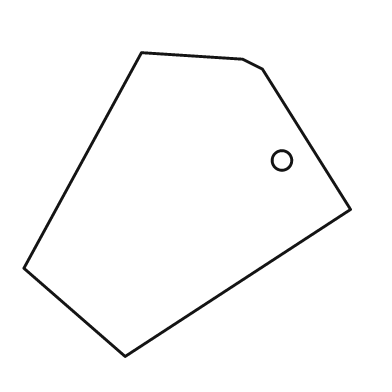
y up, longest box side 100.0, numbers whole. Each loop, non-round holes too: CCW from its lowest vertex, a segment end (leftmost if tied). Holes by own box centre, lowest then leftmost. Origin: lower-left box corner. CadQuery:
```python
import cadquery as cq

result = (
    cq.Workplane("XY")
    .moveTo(31.0, 0.0)
    .lineTo(100.0, 45.0)
    .lineTo(73.0, 88.0)
    .lineTo(67.0, 91.0)
    .lineTo(36.0, 93.0)
    .lineTo(0.0, 27.0)
    .close()
    .moveTo(79.0, 60.0)
    .circle(3.0)
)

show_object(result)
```